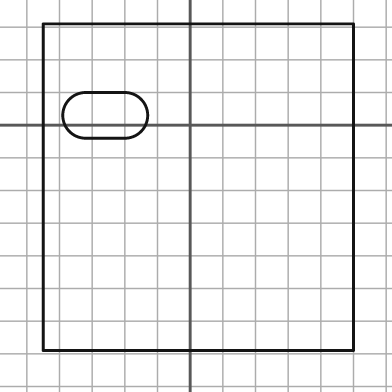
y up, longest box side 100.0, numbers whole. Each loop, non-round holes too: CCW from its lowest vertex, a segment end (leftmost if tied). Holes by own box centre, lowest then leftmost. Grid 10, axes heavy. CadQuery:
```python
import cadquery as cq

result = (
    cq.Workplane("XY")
    .moveTo(-45.0, -69.0)
    .lineTo(50.0, -69.0)
    .lineTo(50.0, 31.0)
    .lineTo(-45.0, 31.0)
    .close()
    .moveTo(-32.0, -4.0)
    .lineTo(-20.0, -4.0)
    .threePointArc((-13.0, 3.0), (-20.0, 10.0))
    .lineTo(-32.0, 10.0)
    .threePointArc((-39.0, 3.0), (-32.0, -4.0))
    .close()
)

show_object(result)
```